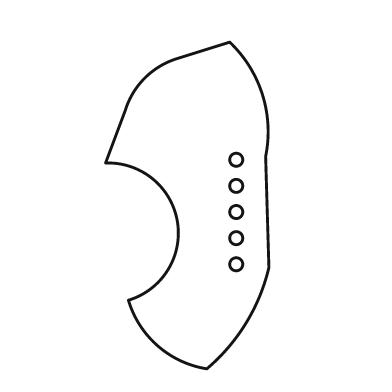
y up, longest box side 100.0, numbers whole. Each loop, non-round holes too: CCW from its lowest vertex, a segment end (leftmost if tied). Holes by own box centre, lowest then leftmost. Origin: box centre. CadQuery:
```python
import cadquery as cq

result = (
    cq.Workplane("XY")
    .moveTo(6.0, -50.0)
    .threePointArc((18.0, -36.0), (25.0, -19.0))
    .lineTo(24.0, 15.0)
    .threePointArc((23.0, 34.0), (13.0, 50.0))
    .lineTo(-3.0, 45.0)
    .threePointArc((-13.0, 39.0), (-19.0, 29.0))
    .lineTo(-25.0, 13.0)
    .threePointArc((-3.0, -5.0), (-18.0, -29.0))
    .threePointArc((-9.0, -43.0), (6.0, -50.0))
    .close()
    .moveTo(15.0, -18.0)
    .circle(2.0)
    .moveTo(15.0, -10.0)
    .circle(2.0)
    .moveTo(15.0, -2.0)
    .circle(2.0)
    .moveTo(15.0, 6.0)
    .circle(2.0)
    .moveTo(15.0, 14.0)
    .circle(2.0)
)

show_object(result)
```